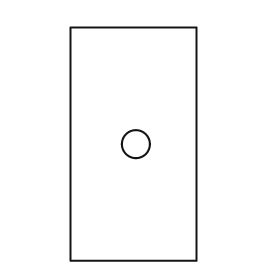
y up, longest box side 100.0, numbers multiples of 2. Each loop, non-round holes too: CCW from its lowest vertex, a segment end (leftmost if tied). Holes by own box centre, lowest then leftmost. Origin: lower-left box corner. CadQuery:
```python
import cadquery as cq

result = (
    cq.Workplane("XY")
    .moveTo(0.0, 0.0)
    .lineTo(54.0, 0.0)
    .lineTo(54.0, 100.0)
    .lineTo(0.0, 100.0)
    .close()
    .moveTo(28.0, 50.0)
    .circle(6.0)
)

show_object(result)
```